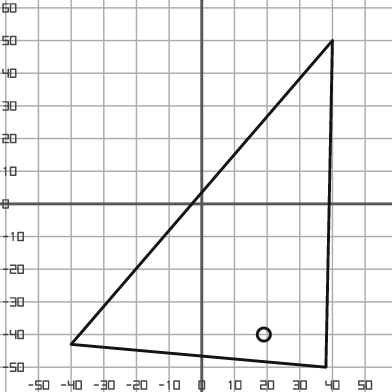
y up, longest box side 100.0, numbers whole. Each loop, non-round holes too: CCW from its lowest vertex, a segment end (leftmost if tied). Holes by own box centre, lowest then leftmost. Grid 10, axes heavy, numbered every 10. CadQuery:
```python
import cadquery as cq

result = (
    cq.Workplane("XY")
    .moveTo(38.0, -50.0)
    .lineTo(40.0, 50.0)
    .lineTo(-40.0, -43.0)
    .close()
    .moveTo(19.0, -40.0)
    .circle(2.0)
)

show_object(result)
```